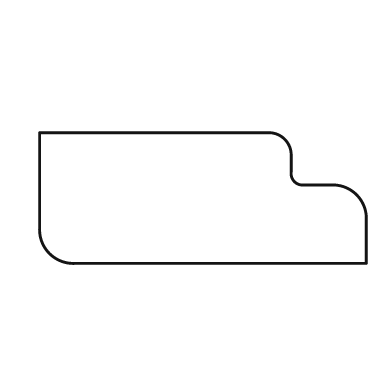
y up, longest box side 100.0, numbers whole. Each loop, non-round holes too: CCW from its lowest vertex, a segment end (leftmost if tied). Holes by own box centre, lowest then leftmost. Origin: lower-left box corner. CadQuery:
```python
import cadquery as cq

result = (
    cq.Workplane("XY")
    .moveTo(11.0, 0.0)
    .lineTo(100.0, 0.0)
    .lineTo(100.0, 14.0)
    .threePointArc((97.0, 21.0), (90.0, 24.0))
    .lineTo(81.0, 24.0)
    .threePointArc((78.0, 25.0), (77.0, 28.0))
    .lineTo(77.0, 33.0)
    .threePointArc((75.0, 38.0), (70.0, 40.0))
    .lineTo(0.0, 40.0)
    .lineTo(0.0, 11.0)
    .threePointArc((3.0, 3.0), (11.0, 0.0))
    .close()
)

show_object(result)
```